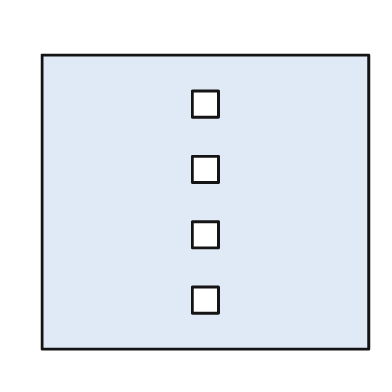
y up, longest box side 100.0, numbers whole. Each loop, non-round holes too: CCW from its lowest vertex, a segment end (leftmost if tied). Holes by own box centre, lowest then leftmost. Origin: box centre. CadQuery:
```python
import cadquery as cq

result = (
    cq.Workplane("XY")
    .moveTo(-50.0, -45.0)
    .lineTo(50.0, -45.0)
    .lineTo(50.0, 45.0)
    .lineTo(-50.0, 45.0)
    .close()
    .moveTo(-4.0, -34.0)
    .lineTo(4.0, -34.0)
    .lineTo(4.0, -26.0)
    .lineTo(-4.0, -26.0)
    .close()
    .moveTo(-4.0, -14.0)
    .lineTo(4.0, -14.0)
    .lineTo(4.0, -6.0)
    .lineTo(-4.0, -6.0)
    .close()
    .moveTo(-4.0, 6.0)
    .lineTo(4.0, 6.0)
    .lineTo(4.0, 14.0)
    .lineTo(-4.0, 14.0)
    .close()
    .moveTo(-4.0, 26.0)
    .lineTo(4.0, 26.0)
    .lineTo(4.0, 34.0)
    .lineTo(-4.0, 34.0)
    .close()
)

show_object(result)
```